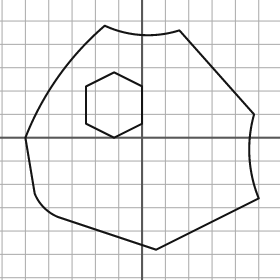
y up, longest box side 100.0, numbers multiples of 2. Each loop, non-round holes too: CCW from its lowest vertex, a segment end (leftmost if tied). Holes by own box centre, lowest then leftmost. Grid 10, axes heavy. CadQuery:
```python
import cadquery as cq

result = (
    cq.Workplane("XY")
    .moveTo(6.0, -48.0)
    .lineTo(50.0, -26.0)
    .threePointArc((46.0, -8.0), (48.0, 10.0))
    .lineTo(16.0, 46.0)
    .threePointArc((0.0, 44.0), (-16.0, 48.0))
    .threePointArc((-36.0, 26.0), (-50.0, 0.0))
    .lineTo(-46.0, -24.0)
    .threePointArc((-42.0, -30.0), (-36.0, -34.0))
    .close()
    .moveTo(-12.0, 0.0)
    .lineTo(0.0, 6.0)
    .lineTo(0.0, 22.0)
    .lineTo(-12.0, 28.0)
    .lineTo(-24.0, 22.0)
    .lineTo(-24.0, 6.0)
    .close()
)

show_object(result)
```